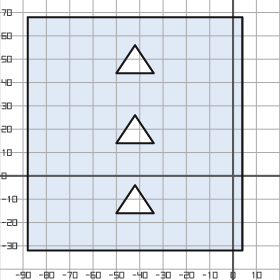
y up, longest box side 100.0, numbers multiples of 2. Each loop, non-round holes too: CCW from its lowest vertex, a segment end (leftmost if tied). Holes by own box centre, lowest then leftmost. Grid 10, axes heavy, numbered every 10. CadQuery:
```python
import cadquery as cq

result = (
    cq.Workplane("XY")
    .moveTo(-88.0, -32.0)
    .lineTo(4.0, -32.0)
    .lineTo(4.0, 68.0)
    .lineTo(-88.0, 68.0)
    .close()
    .moveTo(-50.0, -16.0)
    .lineTo(-34.0, -16.0)
    .lineTo(-42.0, -4.0)
    .close()
    .moveTo(-50.0, 14.0)
    .lineTo(-34.0, 14.0)
    .lineTo(-42.0, 26.0)
    .close()
    .moveTo(-50.0, 44.0)
    .lineTo(-34.0, 44.0)
    .lineTo(-42.0, 56.0)
    .close()
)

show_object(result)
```